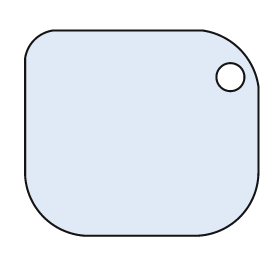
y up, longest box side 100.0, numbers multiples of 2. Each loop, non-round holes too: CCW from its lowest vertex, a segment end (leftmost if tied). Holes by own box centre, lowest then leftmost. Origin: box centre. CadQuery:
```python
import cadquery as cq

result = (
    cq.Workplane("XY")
    .moveTo(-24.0, -44.0)
    .lineTo(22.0, -44.0)
    .threePointArc((42.0, -36.0), (50.0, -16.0))
    .lineTo(50.0, 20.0)
    .threePointArc((42.0, 36.0), (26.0, 44.0))
    .lineTo(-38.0, 44.0)
    .threePointArc((-46.0, 40.0), (-50.0, 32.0))
    .lineTo(-50.0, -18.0)
    .threePointArc((-42.0, -36.0), (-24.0, -44.0))
    .close()
    .moveTo(38.0, 24.0)
    .circle(6.0)
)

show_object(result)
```